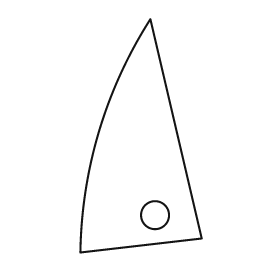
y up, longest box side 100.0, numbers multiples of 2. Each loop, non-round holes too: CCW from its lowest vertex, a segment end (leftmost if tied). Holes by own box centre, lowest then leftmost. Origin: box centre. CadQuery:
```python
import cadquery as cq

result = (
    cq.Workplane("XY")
    .moveTo(-26.0, -50.0)
    .lineTo(26.0, -44.0)
    .lineTo(4.0, 50.0)
    .threePointArc((-18.0, 2.0), (-26.0, -50.0))
    .close()
    .moveTo(6.0, -34.0)
    .circle(6.0)
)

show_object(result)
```